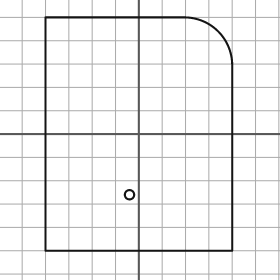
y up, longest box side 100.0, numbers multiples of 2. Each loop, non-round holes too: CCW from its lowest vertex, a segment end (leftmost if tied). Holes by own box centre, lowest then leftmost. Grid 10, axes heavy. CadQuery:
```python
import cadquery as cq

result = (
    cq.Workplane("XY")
    .moveTo(-40.0, -50.0)
    .lineTo(40.0, -50.0)
    .lineTo(40.0, 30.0)
    .threePointArc((34.0, 44.0), (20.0, 50.0))
    .lineTo(-40.0, 50.0)
    .close()
    .moveTo(-4.0, -26.0)
    .circle(2.0)
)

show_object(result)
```